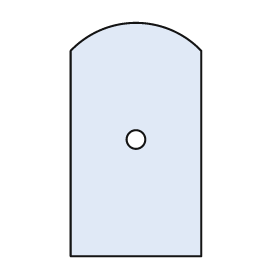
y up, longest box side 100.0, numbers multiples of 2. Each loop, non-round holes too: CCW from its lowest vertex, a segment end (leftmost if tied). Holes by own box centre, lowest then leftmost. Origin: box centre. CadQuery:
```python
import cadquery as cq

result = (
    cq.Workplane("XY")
    .moveTo(-28.0, -50.0)
    .lineTo(28.0, -50.0)
    .lineTo(28.0, 38.0)
    .threePointArc((0.0, 50.0), (-28.0, 38.0))
    .close()
    .moveTo(0.0, 0.0)
    .circle(4.0)
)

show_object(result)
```